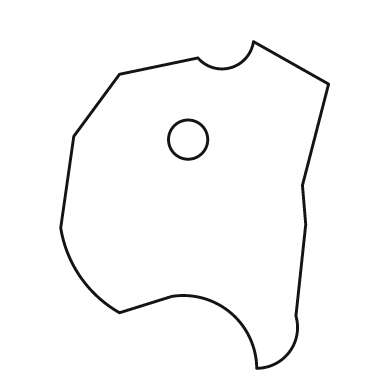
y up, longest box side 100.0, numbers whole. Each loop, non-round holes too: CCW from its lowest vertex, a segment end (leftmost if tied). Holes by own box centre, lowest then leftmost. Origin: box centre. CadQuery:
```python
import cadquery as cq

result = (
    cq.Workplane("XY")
    .moveTo(19.0, -50.0)
    .threePointArc((29.0, -45.0), (31.0, -34.0))
    .lineTo(34.0, -6.0)
    .lineTo(33.0, 6.0)
    .lineTo(41.0, 37.0)
    .lineTo(18.0, 50.0)
    .threePointArc((11.0, 42.0), (1.0, 45.0))
    .lineTo(-23.0, 40.0)
    .lineTo(-37.0, 21.0)
    .lineTo(-41.0, -7.0)
    .threePointArc((-35.0, -22.0), (-23.0, -33.0))
    .lineTo(-7.0, -28.0)
    .threePointArc((11.0, -33.0), (19.0, -50.0))
    .close()
    .moveTo(-2.0, 20.0)
    .circle(6.0)
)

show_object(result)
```